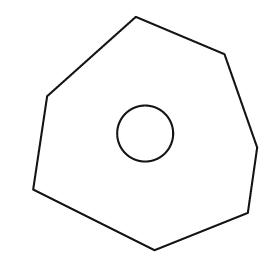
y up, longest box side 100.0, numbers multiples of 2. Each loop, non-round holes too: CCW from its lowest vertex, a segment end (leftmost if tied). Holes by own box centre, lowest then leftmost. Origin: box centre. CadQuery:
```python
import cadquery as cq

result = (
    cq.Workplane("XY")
    .moveTo(4.0, -50.0)
    .lineTo(44.0, -34.0)
    .lineTo(48.0, -6.0)
    .lineTo(34.0, 34.0)
    .lineTo(-4.0, 50.0)
    .lineTo(-42.0, 16.0)
    .lineTo(-48.0, -24.0)
    .close()
    .moveTo(0.0, 0.0)
    .circle(12.0)
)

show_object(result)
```